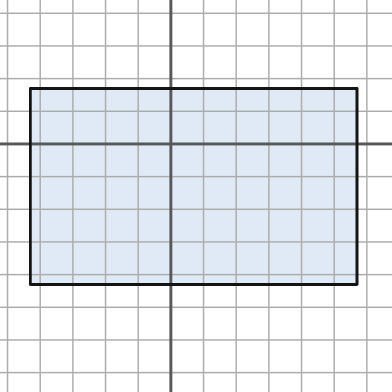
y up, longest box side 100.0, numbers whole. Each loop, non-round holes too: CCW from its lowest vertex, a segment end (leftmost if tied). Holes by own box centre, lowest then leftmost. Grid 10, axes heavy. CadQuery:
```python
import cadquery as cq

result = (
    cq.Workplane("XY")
    .moveTo(-43.0, -43.0)
    .lineTo(57.0, -43.0)
    .lineTo(57.0, 17.0)
    .lineTo(-43.0, 17.0)
    .close()
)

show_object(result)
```